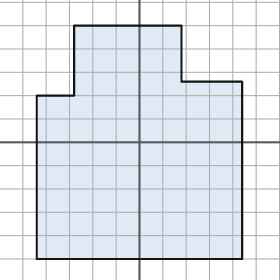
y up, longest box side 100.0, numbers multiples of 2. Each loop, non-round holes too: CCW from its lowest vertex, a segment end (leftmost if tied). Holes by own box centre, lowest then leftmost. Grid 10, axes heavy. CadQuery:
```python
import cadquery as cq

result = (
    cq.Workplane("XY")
    .moveTo(-44.0, -50.0)
    .lineTo(44.0, -50.0)
    .lineTo(44.0, 26.0)
    .lineTo(18.0, 26.0)
    .lineTo(18.0, 50.0)
    .lineTo(-28.0, 50.0)
    .lineTo(-28.0, 20.0)
    .lineTo(-44.0, 20.0)
    .close()
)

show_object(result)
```